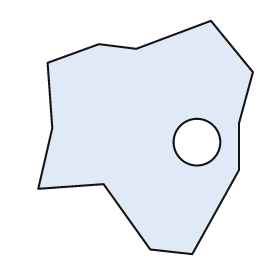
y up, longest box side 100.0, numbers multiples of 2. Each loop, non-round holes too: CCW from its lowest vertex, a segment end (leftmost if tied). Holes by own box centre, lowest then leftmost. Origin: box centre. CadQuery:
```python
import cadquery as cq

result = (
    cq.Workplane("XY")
    .moveTo(20.0, -50.0)
    .lineTo(40.0, -14.0)
    .lineTo(40.0, 6.0)
    .lineTo(46.0, 28.0)
    .lineTo(28.0, 50.0)
    .lineTo(-4.0, 38.0)
    .lineTo(-20.0, 40.0)
    .lineTo(-42.0, 32.0)
    .lineTo(-40.0, 4.0)
    .lineTo(-46.0, -22.0)
    .lineTo(-18.0, -20.0)
    .lineTo(2.0, -48.0)
    .close()
    .moveTo(22.0, -2.0)
    .circle(10.0)
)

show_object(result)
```